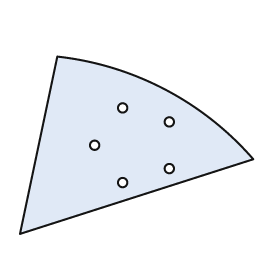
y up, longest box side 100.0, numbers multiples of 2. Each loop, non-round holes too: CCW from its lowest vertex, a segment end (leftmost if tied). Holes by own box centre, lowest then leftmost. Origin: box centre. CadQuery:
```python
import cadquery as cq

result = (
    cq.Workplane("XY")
    .moveTo(-50.0, -38.0)
    .lineTo(50.0, -6.0)
    .threePointArc((12.0, 24.0), (-34.0, 38.0))
    .close()
    .moveTo(-6.0, -16.0)
    .circle(2.0)
    .moveTo(14.0, -10.0)
    .circle(2.0)
    .moveTo(-18.0, 0.0)
    .circle(2.0)
    .moveTo(14.0, 10.0)
    .circle(2.0)
    .moveTo(-6.0, 16.0)
    .circle(2.0)
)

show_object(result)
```